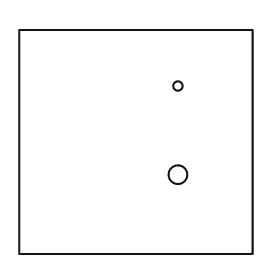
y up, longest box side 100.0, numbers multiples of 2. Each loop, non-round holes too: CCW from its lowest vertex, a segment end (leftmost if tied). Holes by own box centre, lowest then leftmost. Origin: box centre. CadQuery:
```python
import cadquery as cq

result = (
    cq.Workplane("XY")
    .moveTo(-50.0, -48.0)
    .lineTo(50.0, -48.0)
    .lineTo(50.0, 48.0)
    .lineTo(-50.0, 48.0)
    .close()
    .moveTo(18.0, -14.0)
    .circle(4.0)
    .moveTo(18.0, 24.0)
    .circle(2.0)
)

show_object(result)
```